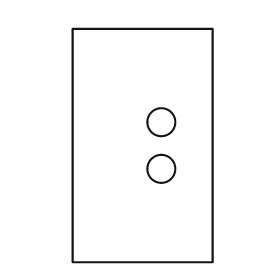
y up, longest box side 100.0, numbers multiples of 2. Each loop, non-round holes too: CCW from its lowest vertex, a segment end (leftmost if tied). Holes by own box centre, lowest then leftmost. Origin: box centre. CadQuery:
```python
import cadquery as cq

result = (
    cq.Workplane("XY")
    .moveTo(-30.0, -50.0)
    .lineTo(30.0, -50.0)
    .lineTo(30.0, 50.0)
    .lineTo(-30.0, 50.0)
    .close()
    .moveTo(8.0, -10.0)
    .circle(6.0)
    .moveTo(8.0, 10.0)
    .circle(6.0)
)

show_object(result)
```